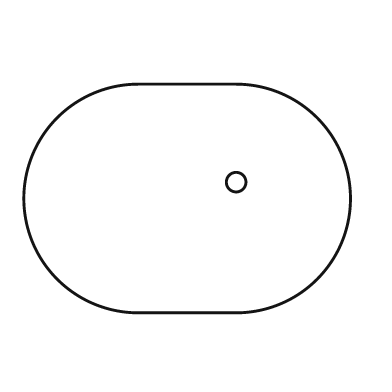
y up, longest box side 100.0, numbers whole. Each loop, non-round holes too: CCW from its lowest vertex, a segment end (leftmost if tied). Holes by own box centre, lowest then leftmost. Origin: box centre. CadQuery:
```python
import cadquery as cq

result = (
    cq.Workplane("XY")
    .moveTo(-15.0, -35.0)
    .lineTo(15.0, -35.0)
    .threePointArc((50.0, 0.0), (15.0, 35.0))
    .lineTo(-15.0, 35.0)
    .threePointArc((-50.0, 0.0), (-15.0, -35.0))
    .close()
    .moveTo(15.0, 5.0)
    .circle(3.0)
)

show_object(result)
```